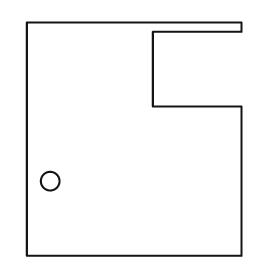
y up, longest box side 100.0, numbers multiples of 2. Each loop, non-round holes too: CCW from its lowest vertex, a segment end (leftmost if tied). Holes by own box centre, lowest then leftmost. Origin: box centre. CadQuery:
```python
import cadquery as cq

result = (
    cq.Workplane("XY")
    .moveTo(-46.0, -50.0)
    .lineTo(46.0, -50.0)
    .lineTo(46.0, 14.0)
    .lineTo(8.0, 14.0)
    .lineTo(8.0, 46.0)
    .lineTo(46.0, 46.0)
    .lineTo(46.0, 50.0)
    .lineTo(-46.0, 50.0)
    .close()
    .moveTo(-36.0, -18.0)
    .circle(4.0)
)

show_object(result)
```